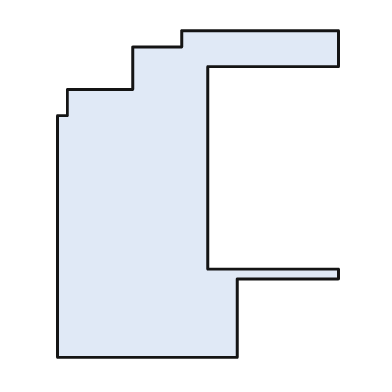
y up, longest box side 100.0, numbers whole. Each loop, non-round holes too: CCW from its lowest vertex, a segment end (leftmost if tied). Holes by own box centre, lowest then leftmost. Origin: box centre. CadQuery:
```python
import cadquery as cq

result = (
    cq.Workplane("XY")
    .moveTo(-43.0, -50.0)
    .lineTo(12.0, -50.0)
    .lineTo(12.0, -26.0)
    .lineTo(43.0, -26.0)
    .lineTo(43.0, -23.0)
    .lineTo(3.0, -23.0)
    .lineTo(3.0, 39.0)
    .lineTo(43.0, 39.0)
    .lineTo(43.0, 50.0)
    .lineTo(-5.0, 50.0)
    .lineTo(-5.0, 45.0)
    .lineTo(-20.0, 45.0)
    .lineTo(-20.0, 32.0)
    .lineTo(-40.0, 32.0)
    .lineTo(-40.0, 24.0)
    .lineTo(-43.0, 24.0)
    .close()
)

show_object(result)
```